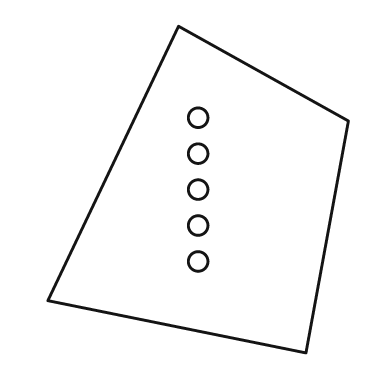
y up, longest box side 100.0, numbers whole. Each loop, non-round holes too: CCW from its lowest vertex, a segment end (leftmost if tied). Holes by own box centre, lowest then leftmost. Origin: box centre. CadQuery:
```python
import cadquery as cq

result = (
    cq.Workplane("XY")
    .moveTo(33.0, -50.0)
    .lineTo(46.0, 21.0)
    .lineTo(-6.0, 50.0)
    .lineTo(-46.0, -34.0)
    .close()
    .moveTo(0.0, -22.0)
    .circle(3.0)
    .moveTo(0.0, -11.0)
    .circle(3.0)
    .moveTo(0.0, 0.0)
    .circle(3.0)
    .moveTo(0.0, 11.0)
    .circle(3.0)
    .moveTo(0.0, 22.0)
    .circle(3.0)
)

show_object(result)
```